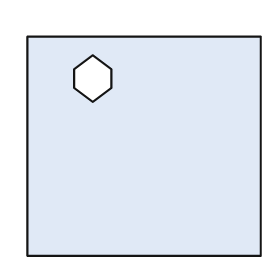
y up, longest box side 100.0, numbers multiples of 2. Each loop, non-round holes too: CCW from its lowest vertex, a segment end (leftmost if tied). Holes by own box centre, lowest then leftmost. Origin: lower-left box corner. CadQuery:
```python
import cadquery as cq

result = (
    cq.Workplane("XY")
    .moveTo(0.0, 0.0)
    .lineTo(100.0, 0.0)
    .lineTo(100.0, 94.0)
    .lineTo(0.0, 94.0)
    .close()
    .moveTo(28.0, 66.0)
    .lineTo(36.0, 72.0)
    .lineTo(36.0, 80.0)
    .lineTo(28.0, 86.0)
    .lineTo(20.0, 80.0)
    .lineTo(20.0, 72.0)
    .close()
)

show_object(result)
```